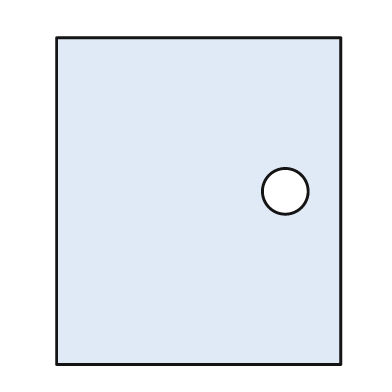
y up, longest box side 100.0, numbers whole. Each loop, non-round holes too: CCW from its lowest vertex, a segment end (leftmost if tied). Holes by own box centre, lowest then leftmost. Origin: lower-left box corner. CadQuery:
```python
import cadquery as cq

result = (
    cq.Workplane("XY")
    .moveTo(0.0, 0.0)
    .lineTo(87.0, 0.0)
    .lineTo(87.0, 100.0)
    .lineTo(0.0, 100.0)
    .close()
    .moveTo(70.0, 53.0)
    .circle(7.0)
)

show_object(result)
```